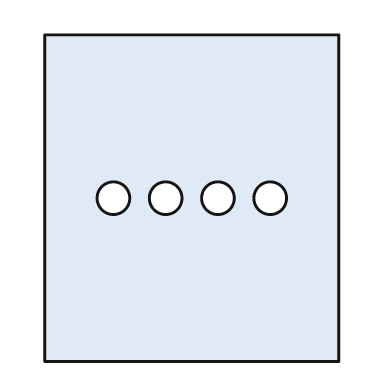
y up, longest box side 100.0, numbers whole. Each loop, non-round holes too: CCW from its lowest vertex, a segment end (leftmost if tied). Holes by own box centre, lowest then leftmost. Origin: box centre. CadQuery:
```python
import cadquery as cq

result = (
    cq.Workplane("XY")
    .moveTo(-45.0, -50.0)
    .lineTo(45.0, -50.0)
    .lineTo(45.0, 50.0)
    .lineTo(-45.0, 50.0)
    .close()
    .moveTo(-24.0, 0.0)
    .circle(5.0)
    .moveTo(-8.0, 0.0)
    .circle(5.0)
    .moveTo(8.0, 0.0)
    .circle(5.0)
    .moveTo(24.0, 0.0)
    .circle(5.0)
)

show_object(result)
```